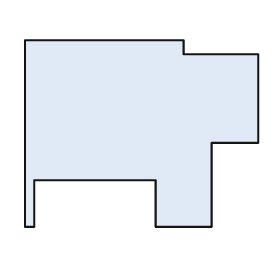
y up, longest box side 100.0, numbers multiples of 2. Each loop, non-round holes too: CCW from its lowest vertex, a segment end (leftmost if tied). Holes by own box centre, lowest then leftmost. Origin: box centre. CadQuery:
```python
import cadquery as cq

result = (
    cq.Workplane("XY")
    .moveTo(-50.0, -40.0)
    .lineTo(-46.0, -40.0)
    .lineTo(-46.0, -20.0)
    .lineTo(6.0, -20.0)
    .lineTo(6.0, -40.0)
    .lineTo(30.0, -40.0)
    .lineTo(30.0, -4.0)
    .lineTo(50.0, -4.0)
    .lineTo(50.0, 34.0)
    .lineTo(18.0, 34.0)
    .lineTo(18.0, 40.0)
    .lineTo(-50.0, 40.0)
    .close()
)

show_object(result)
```